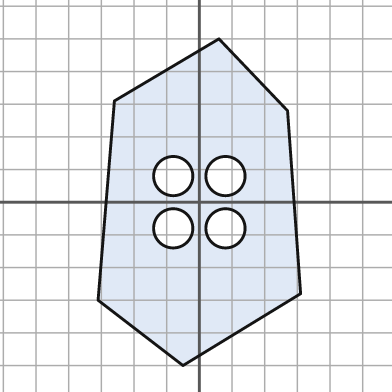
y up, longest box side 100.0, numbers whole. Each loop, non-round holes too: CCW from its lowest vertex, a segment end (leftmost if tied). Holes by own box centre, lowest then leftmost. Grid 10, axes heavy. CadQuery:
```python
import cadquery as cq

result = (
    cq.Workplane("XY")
    .moveTo(-5.0, -50.0)
    .lineTo(31.0, -28.0)
    .lineTo(27.0, 28.0)
    .lineTo(6.0, 50.0)
    .lineTo(-26.0, 31.0)
    .lineTo(-31.0, -30.0)
    .close()
    .moveTo(-8.0, -8.0)
    .circle(6.0)
    .moveTo(8.0, -8.0)
    .circle(6.0)
    .moveTo(-8.0, 8.0)
    .circle(6.0)
    .moveTo(8.0, 8.0)
    .circle(6.0)
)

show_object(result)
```